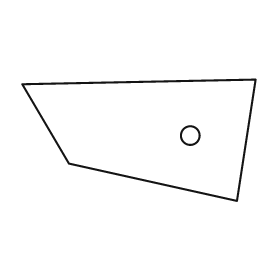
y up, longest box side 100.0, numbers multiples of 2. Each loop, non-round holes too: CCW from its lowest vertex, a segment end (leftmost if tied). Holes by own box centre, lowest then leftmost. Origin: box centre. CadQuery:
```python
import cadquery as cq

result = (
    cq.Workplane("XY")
    .moveTo(42.0, -26.0)
    .lineTo(50.0, 26.0)
    .lineTo(-50.0, 24.0)
    .lineTo(-30.0, -10.0)
    .close()
    .moveTo(22.0, 2.0)
    .circle(4.0)
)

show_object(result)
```